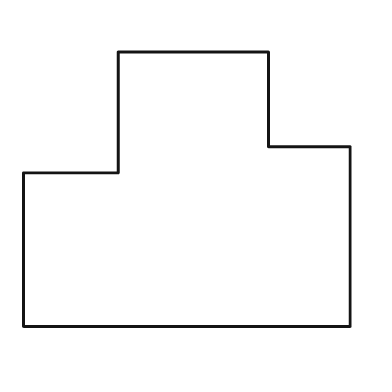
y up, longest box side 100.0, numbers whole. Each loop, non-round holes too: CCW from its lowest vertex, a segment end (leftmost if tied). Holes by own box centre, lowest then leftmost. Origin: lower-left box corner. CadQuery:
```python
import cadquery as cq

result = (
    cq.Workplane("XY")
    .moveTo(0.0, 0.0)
    .lineTo(100.0, 0.0)
    .lineTo(100.0, 55.0)
    .lineTo(75.0, 55.0)
    .lineTo(75.0, 84.0)
    .lineTo(29.0, 84.0)
    .lineTo(29.0, 47.0)
    .lineTo(0.0, 47.0)
    .close()
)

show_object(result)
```